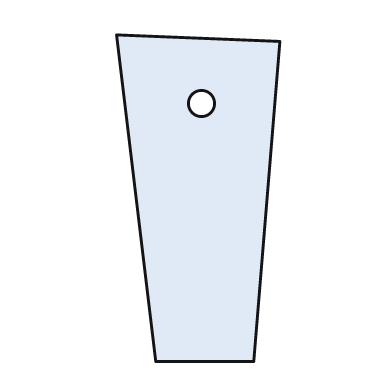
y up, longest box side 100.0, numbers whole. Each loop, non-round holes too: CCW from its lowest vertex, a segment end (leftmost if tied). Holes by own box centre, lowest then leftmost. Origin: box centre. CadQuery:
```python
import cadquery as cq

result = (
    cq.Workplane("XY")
    .moveTo(-13.0, -50.0)
    .lineTo(17.0, -50.0)
    .lineTo(25.0, 48.0)
    .lineTo(-25.0, 50.0)
    .close()
    .moveTo(1.0, 29.0)
    .circle(4.0)
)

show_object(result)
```